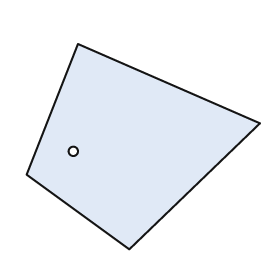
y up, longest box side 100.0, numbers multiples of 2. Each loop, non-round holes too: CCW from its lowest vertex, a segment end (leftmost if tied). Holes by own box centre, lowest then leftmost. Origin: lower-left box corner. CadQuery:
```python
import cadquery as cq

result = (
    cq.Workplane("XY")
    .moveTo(44.0, 0.0)
    .lineTo(100.0, 54.0)
    .lineTo(22.0, 88.0)
    .lineTo(0.0, 32.0)
    .close()
    .moveTo(20.0, 42.0)
    .circle(2.0)
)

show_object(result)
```